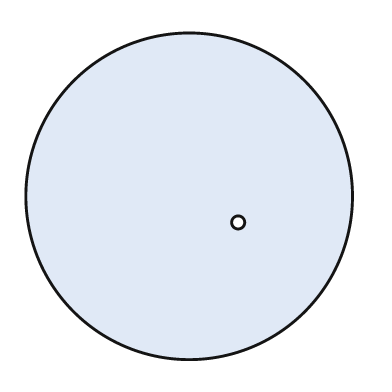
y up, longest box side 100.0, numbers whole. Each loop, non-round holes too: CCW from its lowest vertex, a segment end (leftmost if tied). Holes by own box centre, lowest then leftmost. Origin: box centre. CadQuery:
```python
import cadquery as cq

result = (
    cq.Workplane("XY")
    .moveTo(0.0, 0.0)
    .circle(50.0)
    .moveTo(15.0, -8.0)
    .circle(2.0)
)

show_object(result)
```